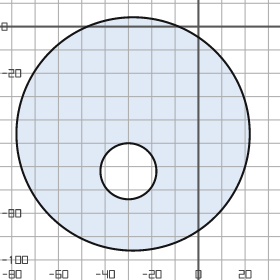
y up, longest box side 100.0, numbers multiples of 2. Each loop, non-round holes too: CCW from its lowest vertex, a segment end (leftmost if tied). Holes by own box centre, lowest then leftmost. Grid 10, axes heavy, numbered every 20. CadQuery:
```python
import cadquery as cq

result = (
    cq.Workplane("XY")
    .moveTo(-28.0, -46.0)
    .circle(50.0)
    .moveTo(-30.0, -62.0)
    .circle(12.0)
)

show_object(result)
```